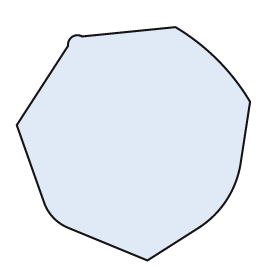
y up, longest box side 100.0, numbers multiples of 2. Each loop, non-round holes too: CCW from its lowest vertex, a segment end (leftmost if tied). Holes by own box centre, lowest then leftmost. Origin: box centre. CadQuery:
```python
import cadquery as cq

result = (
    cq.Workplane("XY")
    .moveTo(6.0, -50.0)
    .lineTo(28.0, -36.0)
    .threePointArc((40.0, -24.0), (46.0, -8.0))
    .lineTo(50.0, 18.0)
    .threePointArc((36.0, 36.0), (18.0, 50.0))
    .lineTo(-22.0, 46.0)
    .threePointArc((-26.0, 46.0), (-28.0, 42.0))
    .lineTo(-50.0, 8.0)
    .lineTo(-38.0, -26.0)
    .threePointArc((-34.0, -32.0), (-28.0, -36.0))
    .close()
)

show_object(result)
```